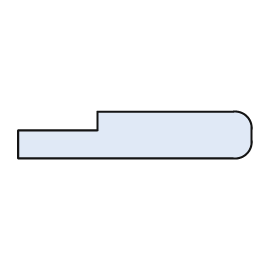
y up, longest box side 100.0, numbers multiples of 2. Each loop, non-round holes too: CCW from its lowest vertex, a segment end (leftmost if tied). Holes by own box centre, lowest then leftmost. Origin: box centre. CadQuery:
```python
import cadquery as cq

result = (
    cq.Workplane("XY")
    .moveTo(-50.0, -10.0)
    .lineTo(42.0, -10.0)
    .threePointArc((48.0, -8.0), (50.0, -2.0))
    .lineTo(50.0, 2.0)
    .threePointArc((48.0, 8.0), (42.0, 10.0))
    .lineTo(-16.0, 10.0)
    .lineTo(-16.0, 2.0)
    .lineTo(-50.0, 2.0)
    .close()
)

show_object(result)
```